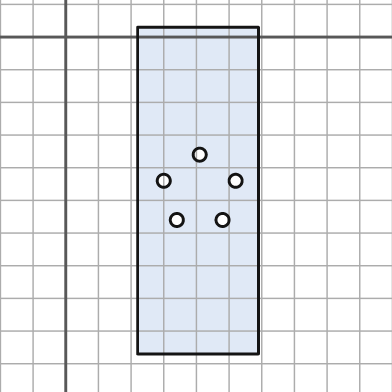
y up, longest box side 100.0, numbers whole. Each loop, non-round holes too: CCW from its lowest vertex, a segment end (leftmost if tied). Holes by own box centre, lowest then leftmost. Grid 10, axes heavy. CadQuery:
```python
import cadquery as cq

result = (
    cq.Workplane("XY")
    .moveTo(22.0, -97.0)
    .lineTo(59.0, -97.0)
    .lineTo(59.0, 3.0)
    .lineTo(22.0, 3.0)
    .close()
    .moveTo(34.0, -56.0)
    .circle(2.0)
    .moveTo(48.0, -56.0)
    .circle(2.0)
    .moveTo(30.0, -44.0)
    .circle(2.0)
    .moveTo(52.0, -44.0)
    .circle(2.0)
    .moveTo(41.0, -36.0)
    .circle(2.0)
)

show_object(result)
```